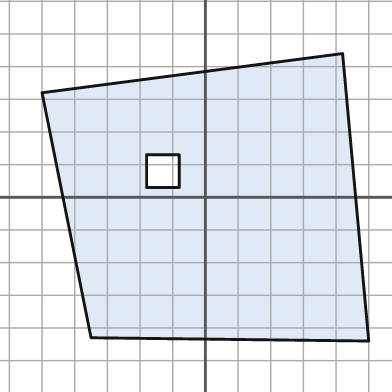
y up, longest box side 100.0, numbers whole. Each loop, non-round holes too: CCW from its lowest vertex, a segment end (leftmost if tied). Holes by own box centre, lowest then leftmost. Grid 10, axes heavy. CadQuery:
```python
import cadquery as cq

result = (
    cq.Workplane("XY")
    .moveTo(50.0, -44.0)
    .lineTo(42.0, 44.0)
    .lineTo(-50.0, 32.0)
    .lineTo(-35.0, -43.0)
    .close()
    .moveTo(-18.0, 3.0)
    .lineTo(-8.0, 3.0)
    .lineTo(-8.0, 13.0)
    .lineTo(-18.0, 13.0)
    .close()
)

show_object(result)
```